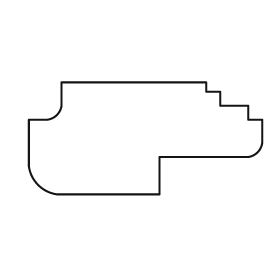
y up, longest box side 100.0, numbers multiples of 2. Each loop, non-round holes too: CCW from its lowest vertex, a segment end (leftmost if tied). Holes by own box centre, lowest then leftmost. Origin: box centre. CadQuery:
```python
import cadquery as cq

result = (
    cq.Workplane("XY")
    .moveTo(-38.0, -24.0)
    .lineTo(6.0, -24.0)
    .lineTo(6.0, -8.0)
    .lineTo(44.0, -8.0)
    .threePointArc((48.0, -6.0), (50.0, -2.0))
    .lineTo(50.0, 8.0)
    .lineTo(44.0, 8.0)
    .lineTo(44.0, 14.0)
    .lineTo(32.0, 14.0)
    .lineTo(32.0, 20.0)
    .lineTo(26.0, 20.0)
    .lineTo(26.0, 24.0)
    .lineTo(-36.0, 24.0)
    .lineTo(-36.0, 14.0)
    .threePointArc((-38.0, 10.0), (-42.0, 8.0))
    .lineTo(-50.0, 8.0)
    .lineTo(-50.0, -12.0)
    .threePointArc((-46.0, -20.0), (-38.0, -24.0))
    .close()
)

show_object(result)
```